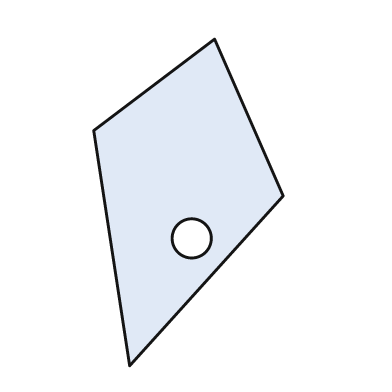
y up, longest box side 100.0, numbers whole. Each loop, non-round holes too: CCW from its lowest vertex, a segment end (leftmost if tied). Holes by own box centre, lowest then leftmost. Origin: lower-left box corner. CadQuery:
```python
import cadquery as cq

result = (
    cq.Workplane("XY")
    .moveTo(11.0, 0.0)
    .lineTo(58.0, 52.0)
    .lineTo(37.0, 100.0)
    .lineTo(0.0, 72.0)
    .close()
    .moveTo(30.0, 39.0)
    .circle(6.0)
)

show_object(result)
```